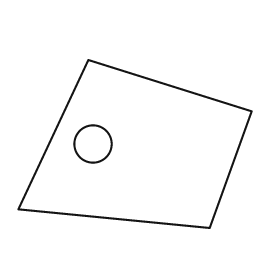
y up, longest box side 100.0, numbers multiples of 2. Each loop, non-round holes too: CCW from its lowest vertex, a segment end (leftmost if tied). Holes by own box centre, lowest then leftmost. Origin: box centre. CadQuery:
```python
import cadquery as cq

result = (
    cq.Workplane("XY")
    .moveTo(32.0, -36.0)
    .lineTo(50.0, 14.0)
    .lineTo(-20.0, 36.0)
    .lineTo(-50.0, -28.0)
    .close()
    .moveTo(-18.0, 0.0)
    .circle(8.0)
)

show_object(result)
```